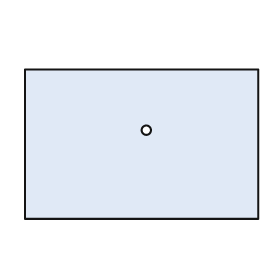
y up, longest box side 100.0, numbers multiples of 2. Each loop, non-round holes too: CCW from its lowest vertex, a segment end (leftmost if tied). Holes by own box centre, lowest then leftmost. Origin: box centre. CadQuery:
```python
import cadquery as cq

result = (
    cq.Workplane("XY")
    .moveTo(-50.0, -32.0)
    .lineTo(50.0, -32.0)
    .lineTo(50.0, 32.0)
    .lineTo(-50.0, 32.0)
    .close()
    .moveTo(2.0, 6.0)
    .circle(2.0)
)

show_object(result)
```